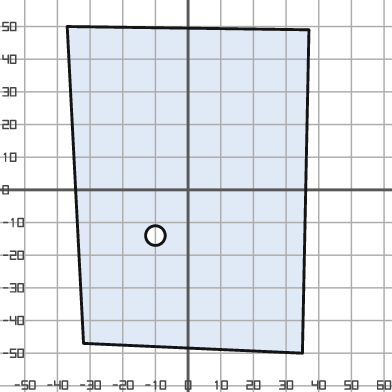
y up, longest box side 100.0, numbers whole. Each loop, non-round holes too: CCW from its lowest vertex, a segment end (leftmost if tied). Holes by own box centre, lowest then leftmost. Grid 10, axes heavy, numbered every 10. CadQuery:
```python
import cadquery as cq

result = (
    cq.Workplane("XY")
    .moveTo(35.0, -50.0)
    .lineTo(37.0, 49.0)
    .lineTo(-37.0, 50.0)
    .lineTo(-32.0, -47.0)
    .close()
    .moveTo(-10.0, -14.0)
    .circle(3.0)
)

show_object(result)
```